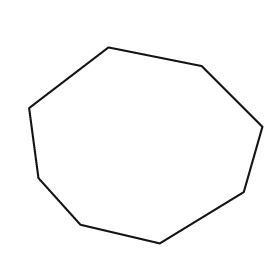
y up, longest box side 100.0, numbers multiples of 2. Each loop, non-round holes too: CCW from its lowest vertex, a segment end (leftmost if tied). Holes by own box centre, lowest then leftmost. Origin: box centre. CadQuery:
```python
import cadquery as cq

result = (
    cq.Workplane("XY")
    .moveTo(6.0, -42.0)
    .lineTo(42.0, -20.0)
    .lineTo(50.0, 8.0)
    .lineTo(24.0, 34.0)
    .lineTo(-16.0, 42.0)
    .lineTo(-50.0, 16.0)
    .lineTo(-46.0, -14.0)
    .lineTo(-28.0, -34.0)
    .close()
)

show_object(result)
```